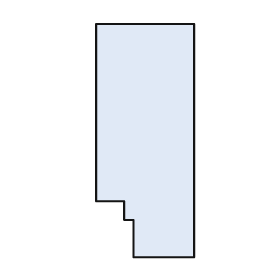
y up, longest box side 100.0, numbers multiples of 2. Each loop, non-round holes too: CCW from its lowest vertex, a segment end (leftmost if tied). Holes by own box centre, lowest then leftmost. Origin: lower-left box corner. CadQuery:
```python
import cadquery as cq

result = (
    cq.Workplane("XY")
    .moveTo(16.0, 0.0)
    .lineTo(42.0, 0.0)
    .lineTo(42.0, 100.0)
    .lineTo(0.0, 100.0)
    .lineTo(0.0, 24.0)
    .lineTo(12.0, 24.0)
    .lineTo(12.0, 16.0)
    .lineTo(16.0, 16.0)
    .close()
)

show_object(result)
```